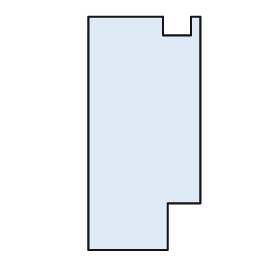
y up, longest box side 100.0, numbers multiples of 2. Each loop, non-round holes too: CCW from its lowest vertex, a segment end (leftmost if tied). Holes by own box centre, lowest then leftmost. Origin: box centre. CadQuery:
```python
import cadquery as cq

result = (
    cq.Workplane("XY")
    .moveTo(-24.0, -50.0)
    .lineTo(10.0, -50.0)
    .lineTo(10.0, -30.0)
    .lineTo(24.0, -30.0)
    .lineTo(24.0, 50.0)
    .lineTo(20.0, 50.0)
    .lineTo(20.0, 42.0)
    .lineTo(8.0, 42.0)
    .lineTo(8.0, 50.0)
    .lineTo(-24.0, 50.0)
    .close()
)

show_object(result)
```